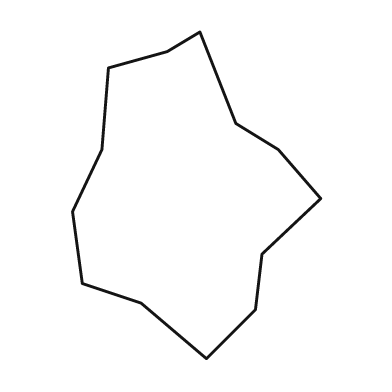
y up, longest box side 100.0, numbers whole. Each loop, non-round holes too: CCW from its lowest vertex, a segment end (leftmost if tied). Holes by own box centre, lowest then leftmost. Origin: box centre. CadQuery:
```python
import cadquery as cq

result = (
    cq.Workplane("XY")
    .moveTo(3.0, -50.0)
    .lineTo(18.0, -35.0)
    .lineTo(20.0, -18.0)
    .lineTo(38.0, -1.0)
    .lineTo(25.0, 14.0)
    .lineTo(12.0, 22.0)
    .lineTo(1.0, 50.0)
    .lineTo(-9.0, 44.0)
    .lineTo(-27.0, 39.0)
    .lineTo(-29.0, 14.0)
    .lineTo(-38.0, -5.0)
    .lineTo(-35.0, -27.0)
    .lineTo(-17.0, -33.0)
    .close()
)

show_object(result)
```